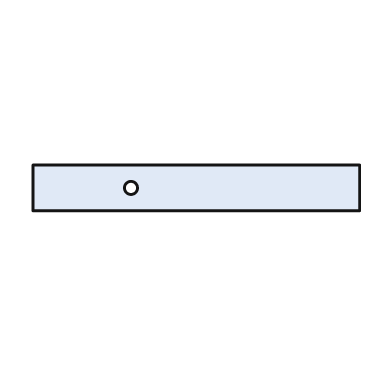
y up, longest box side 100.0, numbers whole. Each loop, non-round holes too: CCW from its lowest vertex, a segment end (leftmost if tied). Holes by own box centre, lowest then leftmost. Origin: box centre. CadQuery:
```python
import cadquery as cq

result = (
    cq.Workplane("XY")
    .moveTo(-50.0, -7.0)
    .lineTo(50.0, -7.0)
    .lineTo(50.0, 7.0)
    .lineTo(-50.0, 7.0)
    .close()
    .moveTo(-20.0, 0.0)
    .circle(2.0)
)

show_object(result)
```